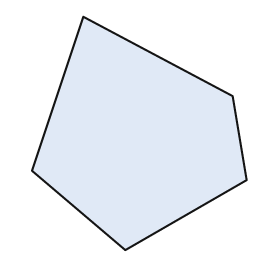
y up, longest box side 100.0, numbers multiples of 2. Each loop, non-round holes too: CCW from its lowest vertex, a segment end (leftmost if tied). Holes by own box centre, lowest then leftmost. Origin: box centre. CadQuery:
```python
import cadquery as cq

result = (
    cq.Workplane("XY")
    .moveTo(-6.0, -50.0)
    .lineTo(46.0, -20.0)
    .lineTo(40.0, 16.0)
    .lineTo(-24.0, 50.0)
    .lineTo(-46.0, -16.0)
    .close()
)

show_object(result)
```